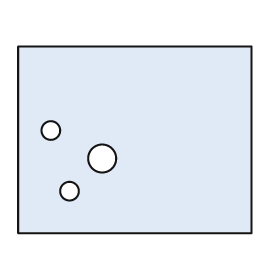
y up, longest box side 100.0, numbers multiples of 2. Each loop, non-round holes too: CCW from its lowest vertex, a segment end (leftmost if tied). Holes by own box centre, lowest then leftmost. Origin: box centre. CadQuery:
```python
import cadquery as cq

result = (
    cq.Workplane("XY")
    .moveTo(-50.0, -40.0)
    .lineTo(50.0, -40.0)
    .lineTo(50.0, 40.0)
    .lineTo(-50.0, 40.0)
    .close()
    .moveTo(-28.0, -22.0)
    .circle(4.0)
    .moveTo(-14.0, -8.0)
    .circle(6.0)
    .moveTo(-36.0, 4.0)
    .circle(4.0)
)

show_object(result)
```